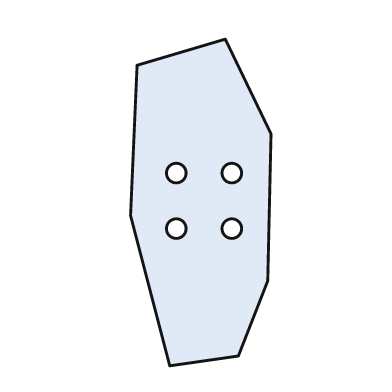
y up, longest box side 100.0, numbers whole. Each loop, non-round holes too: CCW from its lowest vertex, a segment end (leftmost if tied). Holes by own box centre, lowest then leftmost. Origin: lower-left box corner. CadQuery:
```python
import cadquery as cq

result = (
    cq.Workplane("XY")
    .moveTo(12.0, 0.0)
    .lineTo(33.0, 3.0)
    .lineTo(42.0, 26.0)
    .lineTo(43.0, 71.0)
    .lineTo(29.0, 100.0)
    .lineTo(2.0, 92.0)
    .lineTo(0.0, 46.0)
    .close()
    .moveTo(14.0, 42.0)
    .circle(3.0)
    .moveTo(31.0, 42.0)
    .circle(3.0)
    .moveTo(14.0, 59.0)
    .circle(3.0)
    .moveTo(31.0, 59.0)
    .circle(3.0)
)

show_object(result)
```